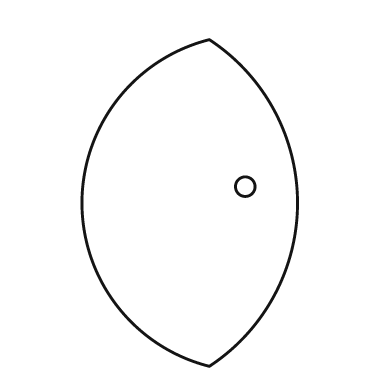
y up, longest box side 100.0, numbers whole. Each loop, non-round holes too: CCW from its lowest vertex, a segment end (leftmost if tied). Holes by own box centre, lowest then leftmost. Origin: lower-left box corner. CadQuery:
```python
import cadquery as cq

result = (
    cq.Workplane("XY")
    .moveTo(39.0, 0.0)
    .threePointArc((66.0, 50.0), (39.0, 100.0))
    .threePointArc((0.0, 50.0), (39.0, 0.0))
    .close()
    .moveTo(50.0, 55.0)
    .circle(3.0)
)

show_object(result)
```